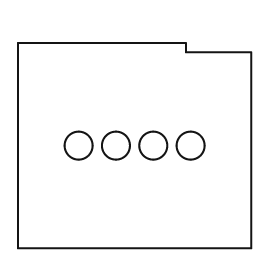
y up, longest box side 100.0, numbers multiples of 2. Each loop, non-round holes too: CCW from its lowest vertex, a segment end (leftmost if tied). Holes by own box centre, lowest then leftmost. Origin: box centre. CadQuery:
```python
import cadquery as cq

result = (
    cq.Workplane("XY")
    .moveTo(-50.0, -44.0)
    .lineTo(50.0, -44.0)
    .lineTo(50.0, 40.0)
    .lineTo(22.0, 40.0)
    .lineTo(22.0, 44.0)
    .lineTo(-50.0, 44.0)
    .close()
    .moveTo(-24.0, 0.0)
    .circle(6.0)
    .moveTo(-8.0, 0.0)
    .circle(6.0)
    .moveTo(8.0, 0.0)
    .circle(6.0)
    .moveTo(24.0, 0.0)
    .circle(6.0)
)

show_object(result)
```